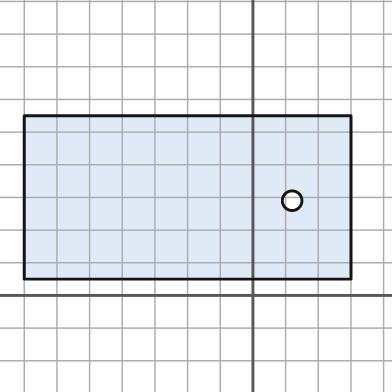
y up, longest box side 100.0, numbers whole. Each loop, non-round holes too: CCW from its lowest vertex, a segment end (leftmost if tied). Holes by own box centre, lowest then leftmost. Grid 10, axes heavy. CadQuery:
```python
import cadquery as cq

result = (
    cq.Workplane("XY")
    .moveTo(-70.0, 5.0)
    .lineTo(30.0, 5.0)
    .lineTo(30.0, 55.0)
    .lineTo(-70.0, 55.0)
    .close()
    .moveTo(12.0, 29.0)
    .circle(3.0)
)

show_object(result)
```